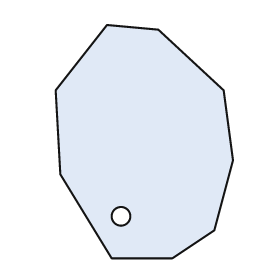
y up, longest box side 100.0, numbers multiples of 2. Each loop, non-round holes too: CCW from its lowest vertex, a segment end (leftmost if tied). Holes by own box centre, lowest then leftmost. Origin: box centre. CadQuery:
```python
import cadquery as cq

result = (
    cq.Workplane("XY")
    .moveTo(-14.0, -50.0)
    .lineTo(12.0, -50.0)
    .lineTo(30.0, -38.0)
    .lineTo(38.0, -8.0)
    .lineTo(34.0, 22.0)
    .lineTo(6.0, 48.0)
    .lineTo(-16.0, 50.0)
    .lineTo(-38.0, 22.0)
    .lineTo(-36.0, -14.0)
    .close()
    .moveTo(-10.0, -32.0)
    .circle(4.0)
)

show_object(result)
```